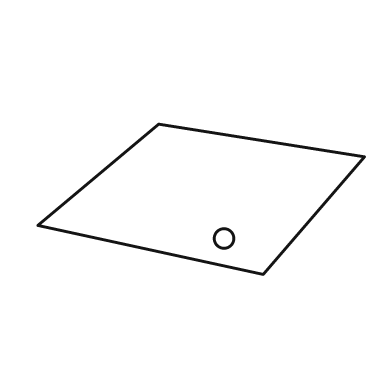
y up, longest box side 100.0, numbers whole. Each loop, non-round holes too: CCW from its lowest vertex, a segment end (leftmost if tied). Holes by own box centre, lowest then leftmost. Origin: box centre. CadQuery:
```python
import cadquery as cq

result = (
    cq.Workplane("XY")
    .moveTo(19.0, -23.0)
    .lineTo(50.0, 13.0)
    .lineTo(-13.0, 23.0)
    .lineTo(-50.0, -8.0)
    .close()
    .moveTo(7.0, -12.0)
    .circle(3.0)
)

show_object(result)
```